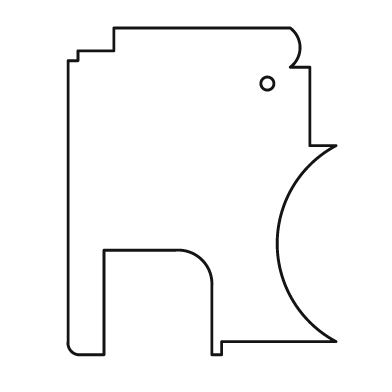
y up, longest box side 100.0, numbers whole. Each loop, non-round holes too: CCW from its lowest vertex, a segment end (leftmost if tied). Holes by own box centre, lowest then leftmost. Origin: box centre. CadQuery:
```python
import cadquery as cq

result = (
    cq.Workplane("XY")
    .moveTo(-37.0, -50.0)
    .lineTo(-30.0, -50.0)
    .lineTo(-30.0, -18.0)
    .lineTo(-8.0, -18.0)
    .threePointArc((0.0, -21.0), (3.0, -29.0))
    .lineTo(3.0, -50.0)
    .lineTo(6.0, -50.0)
    .lineTo(6.0, -46.0)
    .lineTo(41.0, -46.0)
    .threePointArc((23.0, -16.0), (41.0, 14.0))
    .lineTo(33.0, 14.0)
    .lineTo(33.0, 38.0)
    .lineTo(27.0, 38.0)
    .threePointArc((30.0, 44.0), (27.0, 50.0))
    .lineTo(-27.0, 50.0)
    .lineTo(-27.0, 43.0)
    .lineTo(-38.0, 43.0)
    .lineTo(-38.0, 40.0)
    .lineTo(-41.0, 40.0)
    .lineTo(-41.0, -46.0)
    .threePointArc((-40.0, -49.0), (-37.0, -50.0))
    .close()
    .moveTo(20.0, 33.0)
    .circle(2.0)
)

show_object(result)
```